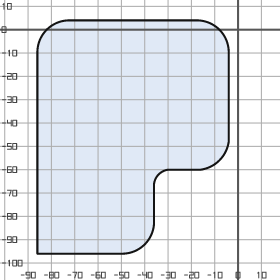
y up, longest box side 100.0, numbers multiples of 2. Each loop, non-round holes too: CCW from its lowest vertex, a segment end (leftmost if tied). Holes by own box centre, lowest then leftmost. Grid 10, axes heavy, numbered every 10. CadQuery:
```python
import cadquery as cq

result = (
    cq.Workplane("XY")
    .moveTo(-86.0, -96.0)
    .lineTo(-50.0, -96.0)
    .threePointArc((-40.0, -92.0), (-36.0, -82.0))
    .lineTo(-36.0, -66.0)
    .threePointArc((-34.0, -62.0), (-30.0, -60.0))
    .lineTo(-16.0, -60.0)
    .threePointArc((-8.0, -56.0), (-4.0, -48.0))
    .lineTo(-4.0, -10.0)
    .threePointArc((-8.0, 0.0), (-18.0, 4.0))
    .lineTo(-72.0, 4.0)
    .threePointArc((-82.0, 0.0), (-86.0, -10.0))
    .close()
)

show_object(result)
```